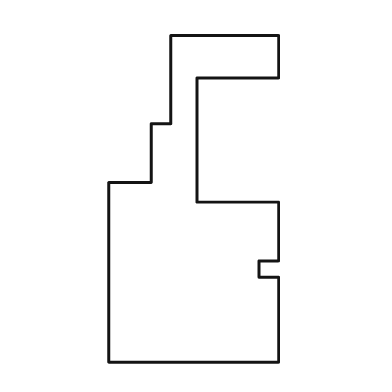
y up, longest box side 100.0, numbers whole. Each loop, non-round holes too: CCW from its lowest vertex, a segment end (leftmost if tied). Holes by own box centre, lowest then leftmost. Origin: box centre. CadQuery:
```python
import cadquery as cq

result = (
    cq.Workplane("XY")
    .moveTo(-26.0, -50.0)
    .lineTo(26.0, -50.0)
    .lineTo(26.0, -24.0)
    .lineTo(20.0, -24.0)
    .lineTo(20.0, -19.0)
    .lineTo(26.0, -19.0)
    .lineTo(26.0, -1.0)
    .lineTo(1.0, -1.0)
    .lineTo(1.0, 37.0)
    .lineTo(26.0, 37.0)
    .lineTo(26.0, 50.0)
    .lineTo(-7.0, 50.0)
    .lineTo(-7.0, 23.0)
    .lineTo(-13.0, 23.0)
    .lineTo(-13.0, 5.0)
    .lineTo(-26.0, 5.0)
    .close()
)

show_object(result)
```